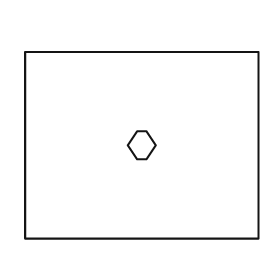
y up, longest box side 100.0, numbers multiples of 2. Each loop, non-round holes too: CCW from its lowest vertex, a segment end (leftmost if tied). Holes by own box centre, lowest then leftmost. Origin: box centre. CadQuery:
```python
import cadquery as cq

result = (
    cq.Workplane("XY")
    .moveTo(-50.0, -40.0)
    .lineTo(50.0, -40.0)
    .lineTo(50.0, 40.0)
    .lineTo(-50.0, 40.0)
    .close()
    .moveTo(-2.0, -6.0)
    .lineTo(2.0, -6.0)
    .lineTo(6.0, 0.0)
    .lineTo(2.0, 6.0)
    .lineTo(-2.0, 6.0)
    .lineTo(-6.0, 0.0)
    .close()
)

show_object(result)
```